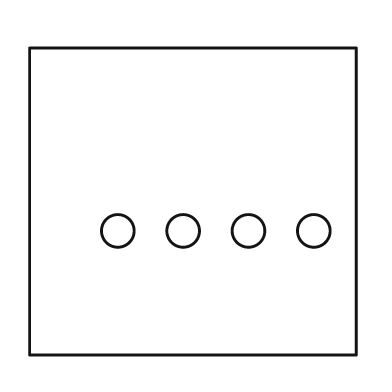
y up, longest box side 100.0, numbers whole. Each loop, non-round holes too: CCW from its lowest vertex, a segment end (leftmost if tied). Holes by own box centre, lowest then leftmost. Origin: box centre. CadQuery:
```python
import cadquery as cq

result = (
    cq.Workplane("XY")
    .moveTo(-50.0, -47.0)
    .lineTo(50.0, -47.0)
    .lineTo(50.0, 47.0)
    .lineTo(-50.0, 47.0)
    .close()
    .moveTo(-23.0, -9.0)
    .circle(5.0)
    .moveTo(-3.0, -9.0)
    .circle(5.0)
    .moveTo(17.0, -9.0)
    .circle(5.0)
    .moveTo(37.0, -9.0)
    .circle(5.0)
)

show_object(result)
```